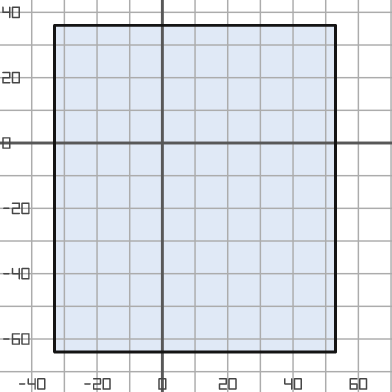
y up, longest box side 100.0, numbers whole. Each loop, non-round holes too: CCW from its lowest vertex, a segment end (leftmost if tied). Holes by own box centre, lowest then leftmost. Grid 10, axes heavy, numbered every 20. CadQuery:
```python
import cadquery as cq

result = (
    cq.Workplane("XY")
    .moveTo(-33.0, -64.0)
    .lineTo(53.0, -64.0)
    .lineTo(53.0, 36.0)
    .lineTo(-33.0, 36.0)
    .close()
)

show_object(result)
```